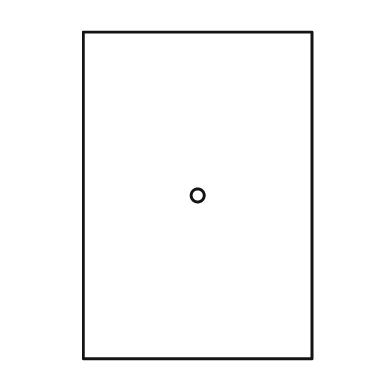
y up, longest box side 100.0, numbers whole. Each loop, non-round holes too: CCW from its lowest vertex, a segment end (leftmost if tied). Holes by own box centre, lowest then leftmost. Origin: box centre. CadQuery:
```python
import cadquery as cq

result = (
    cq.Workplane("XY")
    .moveTo(-35.0, -50.0)
    .lineTo(35.0, -50.0)
    .lineTo(35.0, 50.0)
    .lineTo(-35.0, 50.0)
    .close()
    .moveTo(0.0, 0.0)
    .circle(2.0)
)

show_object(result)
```